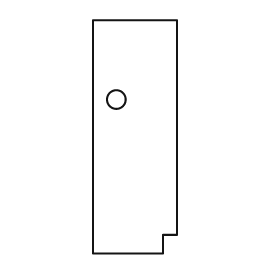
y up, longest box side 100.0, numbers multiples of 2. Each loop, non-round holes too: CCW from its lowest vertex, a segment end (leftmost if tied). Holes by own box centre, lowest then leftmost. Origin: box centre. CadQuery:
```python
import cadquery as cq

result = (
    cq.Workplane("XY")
    .moveTo(-18.0, -50.0)
    .lineTo(12.0, -50.0)
    .lineTo(12.0, -42.0)
    .lineTo(18.0, -42.0)
    .lineTo(18.0, 50.0)
    .lineTo(-18.0, 50.0)
    .close()
    .moveTo(-8.0, 16.0)
    .circle(4.0)
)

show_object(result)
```